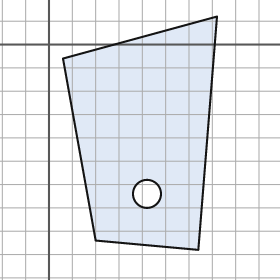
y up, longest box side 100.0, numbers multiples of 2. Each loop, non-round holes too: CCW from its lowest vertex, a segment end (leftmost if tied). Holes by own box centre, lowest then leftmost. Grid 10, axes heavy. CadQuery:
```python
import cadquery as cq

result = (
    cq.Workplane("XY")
    .moveTo(64.0, -88.0)
    .lineTo(72.0, 12.0)
    .lineTo(6.0, -6.0)
    .lineTo(20.0, -84.0)
    .close()
    .moveTo(42.0, -64.0)
    .circle(6.0)
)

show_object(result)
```